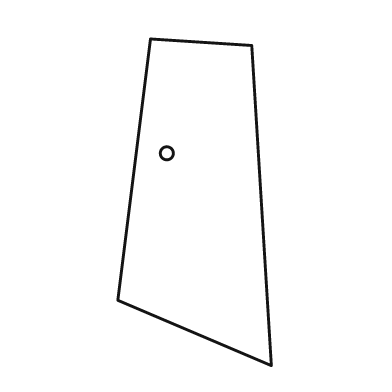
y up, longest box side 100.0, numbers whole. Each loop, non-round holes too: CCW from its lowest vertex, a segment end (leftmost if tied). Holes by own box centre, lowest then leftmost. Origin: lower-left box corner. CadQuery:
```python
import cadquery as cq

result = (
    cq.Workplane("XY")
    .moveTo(47.0, 0.0)
    .lineTo(41.0, 98.0)
    .lineTo(10.0, 100.0)
    .lineTo(0.0, 20.0)
    .close()
    .moveTo(15.0, 65.0)
    .circle(2.0)
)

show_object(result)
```